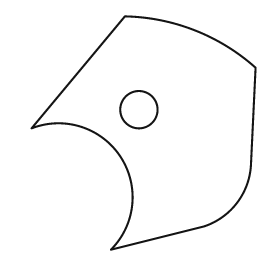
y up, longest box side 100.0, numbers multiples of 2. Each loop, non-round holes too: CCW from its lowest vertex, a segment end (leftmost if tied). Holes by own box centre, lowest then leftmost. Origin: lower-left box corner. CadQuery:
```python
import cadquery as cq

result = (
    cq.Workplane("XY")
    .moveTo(34.0, 0.0)
    .lineTo(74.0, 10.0)
    .threePointArc((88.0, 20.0), (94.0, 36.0))
    .lineTo(96.0, 78.0)
    .threePointArc((70.0, 94.0), (40.0, 100.0))
    .lineTo(0.0, 52.0)
    .threePointArc((38.0, 40.0), (34.0, 0.0))
    .close()
    .moveTo(46.0, 60.0)
    .circle(8.0)
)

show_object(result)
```